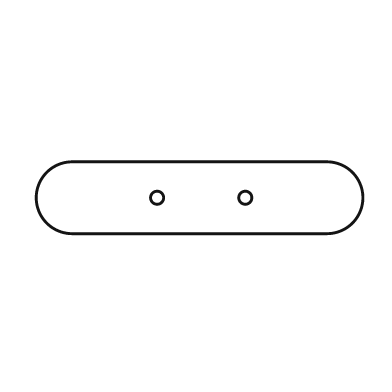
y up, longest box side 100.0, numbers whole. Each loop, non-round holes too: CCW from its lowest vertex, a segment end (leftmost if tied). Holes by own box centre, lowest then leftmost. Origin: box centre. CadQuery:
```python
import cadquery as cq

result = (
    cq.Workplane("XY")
    .moveTo(-39.0, -11.0)
    .lineTo(39.0, -11.0)
    .threePointArc((50.0, 0.0), (39.0, 11.0))
    .lineTo(-39.0, 11.0)
    .threePointArc((-50.0, 0.0), (-39.0, -11.0))
    .close()
    .moveTo(-13.0, 0.0)
    .circle(2.0)
    .moveTo(14.0, 0.0)
    .circle(2.0)
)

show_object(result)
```